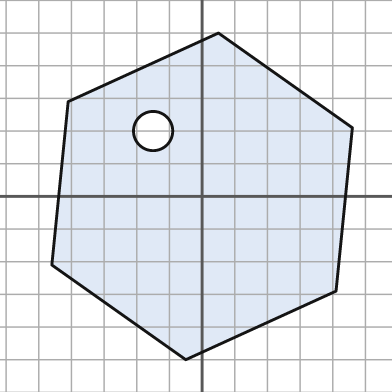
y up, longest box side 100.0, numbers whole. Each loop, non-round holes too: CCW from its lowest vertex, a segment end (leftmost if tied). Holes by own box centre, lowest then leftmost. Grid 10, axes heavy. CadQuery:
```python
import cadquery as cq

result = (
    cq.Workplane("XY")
    .moveTo(-5.0, -50.0)
    .lineTo(41.0, -29.0)
    .lineTo(46.0, 21.0)
    .lineTo(5.0, 50.0)
    .lineTo(-41.0, 29.0)
    .lineTo(-46.0, -21.0)
    .close()
    .moveTo(-15.0, 20.0)
    .circle(6.0)
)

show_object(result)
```